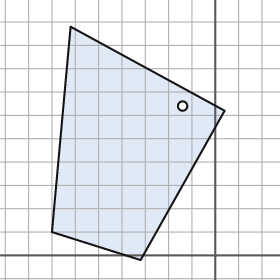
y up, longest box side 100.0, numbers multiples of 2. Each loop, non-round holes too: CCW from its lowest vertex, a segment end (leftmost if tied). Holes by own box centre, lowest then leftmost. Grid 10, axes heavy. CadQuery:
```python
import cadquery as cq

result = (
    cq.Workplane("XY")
    .moveTo(-32.0, -2.0)
    .lineTo(4.0, 62.0)
    .lineTo(-62.0, 98.0)
    .lineTo(-70.0, 10.0)
    .close()
    .moveTo(-14.0, 64.0)
    .circle(2.0)
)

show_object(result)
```